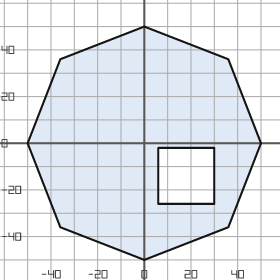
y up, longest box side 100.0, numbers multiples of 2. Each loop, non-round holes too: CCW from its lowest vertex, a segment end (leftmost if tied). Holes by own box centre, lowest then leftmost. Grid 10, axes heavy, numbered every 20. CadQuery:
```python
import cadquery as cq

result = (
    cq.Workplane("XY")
    .moveTo(0.0, -50.0)
    .lineTo(36.0, -36.0)
    .lineTo(50.0, 0.0)
    .lineTo(36.0, 36.0)
    .lineTo(0.0, 50.0)
    .lineTo(-36.0, 36.0)
    .lineTo(-50.0, 0.0)
    .lineTo(-36.0, -36.0)
    .close()
    .moveTo(6.0, -26.0)
    .lineTo(30.0, -26.0)
    .lineTo(30.0, -2.0)
    .lineTo(6.0, -2.0)
    .close()
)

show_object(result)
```